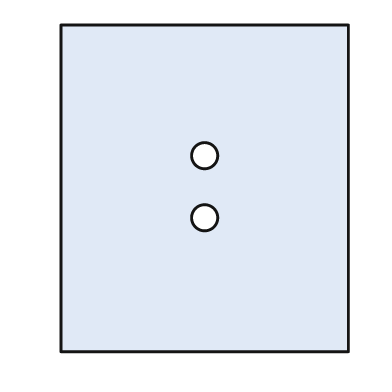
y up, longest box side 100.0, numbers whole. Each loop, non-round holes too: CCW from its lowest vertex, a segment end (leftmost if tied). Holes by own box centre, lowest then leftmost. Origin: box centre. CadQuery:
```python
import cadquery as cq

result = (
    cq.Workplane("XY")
    .moveTo(-44.0, -50.0)
    .lineTo(44.0, -50.0)
    .lineTo(44.0, 50.0)
    .lineTo(-44.0, 50.0)
    .close()
    .moveTo(0.0, -9.0)
    .circle(4.0)
    .moveTo(0.0, 10.0)
    .circle(4.0)
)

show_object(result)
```